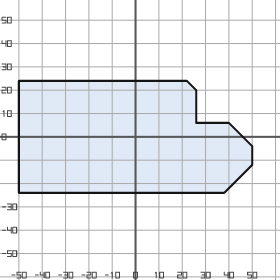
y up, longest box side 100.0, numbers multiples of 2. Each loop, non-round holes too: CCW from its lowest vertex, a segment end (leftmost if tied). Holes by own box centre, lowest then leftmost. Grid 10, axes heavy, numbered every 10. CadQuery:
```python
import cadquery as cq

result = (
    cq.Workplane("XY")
    .moveTo(-50.0, -24.0)
    .lineTo(38.0, -24.0)
    .lineTo(50.0, -12.0)
    .lineTo(50.0, -4.0)
    .lineTo(40.0, 6.0)
    .lineTo(26.0, 6.0)
    .lineTo(26.0, 20.0)
    .lineTo(22.0, 24.0)
    .lineTo(-50.0, 24.0)
    .close()
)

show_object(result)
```